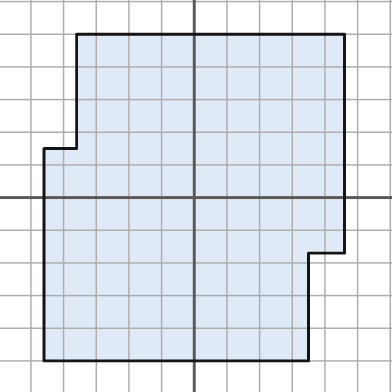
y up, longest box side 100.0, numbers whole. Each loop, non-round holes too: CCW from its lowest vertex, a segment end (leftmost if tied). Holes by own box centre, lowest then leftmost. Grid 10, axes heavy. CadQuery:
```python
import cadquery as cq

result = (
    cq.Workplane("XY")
    .moveTo(-46.0, -50.0)
    .lineTo(35.0, -50.0)
    .lineTo(35.0, -17.0)
    .lineTo(46.0, -17.0)
    .lineTo(46.0, 50.0)
    .lineTo(-36.0, 50.0)
    .lineTo(-36.0, 15.0)
    .lineTo(-46.0, 15.0)
    .close()
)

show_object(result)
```